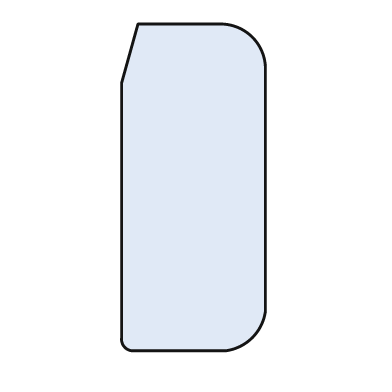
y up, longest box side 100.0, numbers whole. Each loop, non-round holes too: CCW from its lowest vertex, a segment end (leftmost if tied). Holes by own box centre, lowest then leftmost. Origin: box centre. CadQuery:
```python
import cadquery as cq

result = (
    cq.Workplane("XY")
    .moveTo(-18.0, -50.0)
    .lineTo(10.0, -50.0)
    .threePointArc((18.0, -46.0), (22.0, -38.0))
    .lineTo(22.0, 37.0)
    .threePointArc((18.0, 46.0), (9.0, 50.0))
    .lineTo(-17.0, 50.0)
    .lineTo(-22.0, 32.0)
    .lineTo(-22.0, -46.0)
    .threePointArc((-21.0, -49.0), (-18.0, -50.0))
    .close()
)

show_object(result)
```